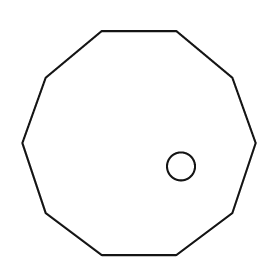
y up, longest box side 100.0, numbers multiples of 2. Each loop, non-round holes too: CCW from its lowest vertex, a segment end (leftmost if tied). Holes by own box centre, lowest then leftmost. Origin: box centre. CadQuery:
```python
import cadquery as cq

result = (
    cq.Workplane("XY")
    .moveTo(-16.0, -48.0)
    .lineTo(16.0, -48.0)
    .lineTo(40.0, -30.0)
    .lineTo(50.0, 0.0)
    .lineTo(40.0, 28.0)
    .lineTo(16.0, 48.0)
    .lineTo(-16.0, 48.0)
    .lineTo(-40.0, 28.0)
    .lineTo(-50.0, 0.0)
    .lineTo(-40.0, -30.0)
    .close()
    .moveTo(18.0, -10.0)
    .circle(6.0)
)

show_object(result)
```